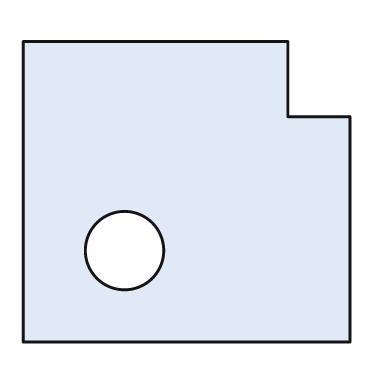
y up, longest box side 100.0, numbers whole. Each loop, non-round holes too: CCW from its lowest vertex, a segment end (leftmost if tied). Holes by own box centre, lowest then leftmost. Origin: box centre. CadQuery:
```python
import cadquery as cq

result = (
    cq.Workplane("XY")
    .moveTo(-50.0, -46.0)
    .lineTo(50.0, -46.0)
    .lineTo(50.0, 23.0)
    .lineTo(31.0, 23.0)
    .lineTo(31.0, 46.0)
    .lineTo(-50.0, 46.0)
    .close()
    .moveTo(-19.0, -18.0)
    .circle(12.0)
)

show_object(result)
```